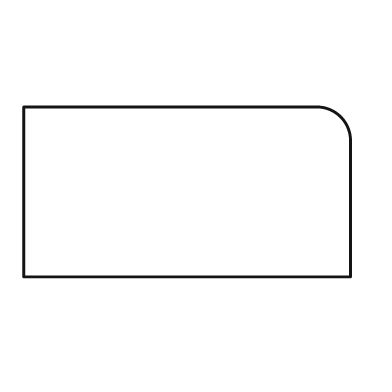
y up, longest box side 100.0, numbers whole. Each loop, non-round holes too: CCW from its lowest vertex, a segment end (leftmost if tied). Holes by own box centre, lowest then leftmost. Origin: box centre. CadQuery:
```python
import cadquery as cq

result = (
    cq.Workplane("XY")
    .moveTo(-50.0, -26.0)
    .lineTo(50.0, -26.0)
    .lineTo(50.0, 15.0)
    .threePointArc((47.0, 23.0), (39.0, 26.0))
    .lineTo(-50.0, 26.0)
    .close()
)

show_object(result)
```